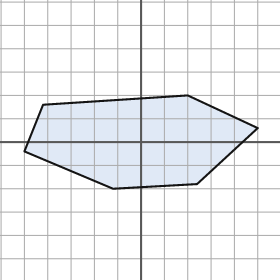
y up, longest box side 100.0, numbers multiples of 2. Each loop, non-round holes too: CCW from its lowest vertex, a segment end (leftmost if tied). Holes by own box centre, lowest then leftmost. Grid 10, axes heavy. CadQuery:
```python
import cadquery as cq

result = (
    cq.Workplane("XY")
    .moveTo(-12.0, -20.0)
    .lineTo(24.0, -18.0)
    .lineTo(50.0, 6.0)
    .lineTo(20.0, 20.0)
    .lineTo(-42.0, 16.0)
    .lineTo(-50.0, -4.0)
    .close()
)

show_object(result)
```